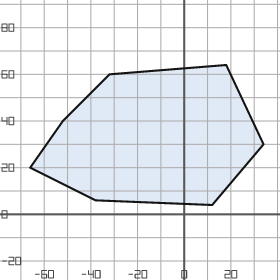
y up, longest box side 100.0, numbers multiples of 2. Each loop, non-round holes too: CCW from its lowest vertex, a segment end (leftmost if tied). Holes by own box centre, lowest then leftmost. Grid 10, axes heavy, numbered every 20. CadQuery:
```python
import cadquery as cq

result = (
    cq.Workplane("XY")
    .moveTo(12.0, 4.0)
    .lineTo(34.0, 30.0)
    .lineTo(18.0, 64.0)
    .lineTo(-32.0, 60.0)
    .lineTo(-52.0, 40.0)
    .lineTo(-66.0, 20.0)
    .lineTo(-38.0, 6.0)
    .close()
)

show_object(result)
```